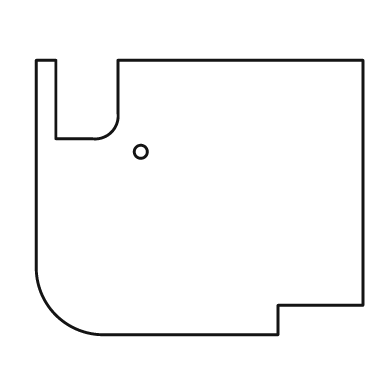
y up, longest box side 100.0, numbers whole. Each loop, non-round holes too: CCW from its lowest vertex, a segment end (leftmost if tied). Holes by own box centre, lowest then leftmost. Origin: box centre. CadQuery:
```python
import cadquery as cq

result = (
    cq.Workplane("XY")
    .moveTo(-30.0, -42.0)
    .lineTo(24.0, -42.0)
    .lineTo(24.0, -33.0)
    .lineTo(50.0, -33.0)
    .lineTo(50.0, 42.0)
    .lineTo(-25.0, 42.0)
    .lineTo(-25.0, 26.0)
    .threePointArc((-27.0, 20.0), (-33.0, 18.0))
    .lineTo(-44.0, 18.0)
    .lineTo(-44.0, 42.0)
    .lineTo(-50.0, 42.0)
    .lineTo(-50.0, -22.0)
    .threePointArc((-44.0, -36.0), (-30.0, -42.0))
    .close()
    .moveTo(-18.0, 14.0)
    .circle(2.0)
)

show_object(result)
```